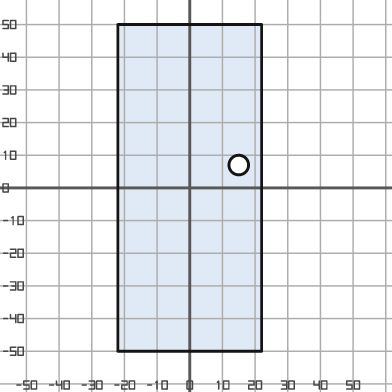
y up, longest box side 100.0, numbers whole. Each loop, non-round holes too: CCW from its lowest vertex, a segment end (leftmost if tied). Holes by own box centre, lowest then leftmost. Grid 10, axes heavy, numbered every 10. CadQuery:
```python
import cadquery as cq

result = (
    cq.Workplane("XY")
    .moveTo(-22.0, -50.0)
    .lineTo(22.0, -50.0)
    .lineTo(22.0, 50.0)
    .lineTo(-22.0, 50.0)
    .close()
    .moveTo(15.0, 7.0)
    .circle(3.0)
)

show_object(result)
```